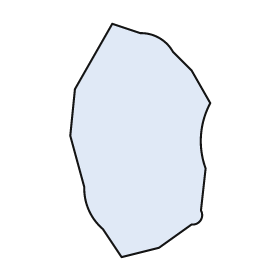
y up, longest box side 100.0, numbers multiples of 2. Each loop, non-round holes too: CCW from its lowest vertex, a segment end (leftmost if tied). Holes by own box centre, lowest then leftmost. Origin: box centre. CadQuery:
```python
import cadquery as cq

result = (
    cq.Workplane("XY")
    .moveTo(-8.0, -50.0)
    .lineTo(8.0, -46.0)
    .lineTo(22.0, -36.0)
    .threePointArc((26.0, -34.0), (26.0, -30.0))
    .lineTo(28.0, -12.0)
    .threePointArc((26.0, 2.0), (30.0, 16.0))
    .lineTo(22.0, 30.0)
    .lineTo(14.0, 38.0)
    .threePointArc((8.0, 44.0), (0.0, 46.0))
    .lineTo(-12.0, 50.0)
    .lineTo(-28.0, 22.0)
    .lineTo(-30.0, 2.0)
    .lineTo(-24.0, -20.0)
    .threePointArc((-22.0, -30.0), (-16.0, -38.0))
    .close()
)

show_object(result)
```